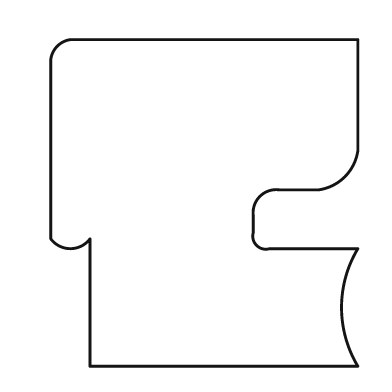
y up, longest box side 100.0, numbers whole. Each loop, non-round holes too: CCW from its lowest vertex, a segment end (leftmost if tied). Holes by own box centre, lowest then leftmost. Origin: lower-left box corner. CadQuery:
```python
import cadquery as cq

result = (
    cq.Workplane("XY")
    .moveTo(12.0, 0.0)
    .lineTo(94.0, 0.0)
    .threePointArc((89.0, 18.0), (94.0, 36.0))
    .lineTo(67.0, 36.0)
    .threePointArc((63.0, 37.0), (62.0, 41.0))
    .lineTo(62.0, 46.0)
    .threePointArc((64.0, 52.0), (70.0, 54.0))
    .lineTo(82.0, 54.0)
    .threePointArc((90.0, 58.0), (94.0, 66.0))
    .lineTo(94.0, 100.0)
    .lineTo(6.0, 100.0)
    .threePointArc((2.0, 98.0), (0.0, 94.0))
    .lineTo(0.0, 39.0)
    .threePointArc((6.0, 36.0), (12.0, 39.0))
    .close()
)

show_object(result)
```